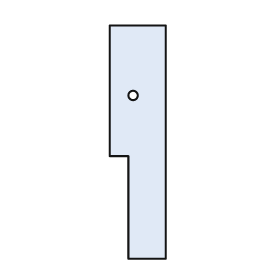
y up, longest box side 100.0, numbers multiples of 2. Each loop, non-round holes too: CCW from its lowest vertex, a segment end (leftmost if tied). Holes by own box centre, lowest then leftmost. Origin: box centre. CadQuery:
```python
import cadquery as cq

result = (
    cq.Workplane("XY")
    .moveTo(-4.0, -50.0)
    .lineTo(12.0, -50.0)
    .lineTo(12.0, 50.0)
    .lineTo(-12.0, 50.0)
    .lineTo(-12.0, -6.0)
    .lineTo(-4.0, -6.0)
    .close()
    .moveTo(-2.0, 20.0)
    .circle(2.0)
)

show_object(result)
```